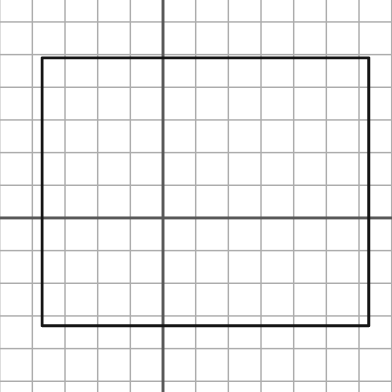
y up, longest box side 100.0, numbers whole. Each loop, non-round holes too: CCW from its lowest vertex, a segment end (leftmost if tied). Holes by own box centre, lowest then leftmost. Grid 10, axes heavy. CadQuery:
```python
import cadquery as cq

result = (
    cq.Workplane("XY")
    .moveTo(-37.0, -33.0)
    .lineTo(63.0, -33.0)
    .lineTo(63.0, 49.0)
    .lineTo(-37.0, 49.0)
    .close()
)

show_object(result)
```